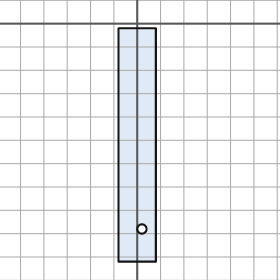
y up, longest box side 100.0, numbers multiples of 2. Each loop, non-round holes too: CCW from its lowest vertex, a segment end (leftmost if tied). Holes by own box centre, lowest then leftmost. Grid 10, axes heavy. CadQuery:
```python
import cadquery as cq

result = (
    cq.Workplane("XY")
    .moveTo(-8.0, -102.0)
    .lineTo(8.0, -102.0)
    .lineTo(8.0, -2.0)
    .lineTo(-8.0, -2.0)
    .close()
    .moveTo(2.0, -88.0)
    .circle(2.0)
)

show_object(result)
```